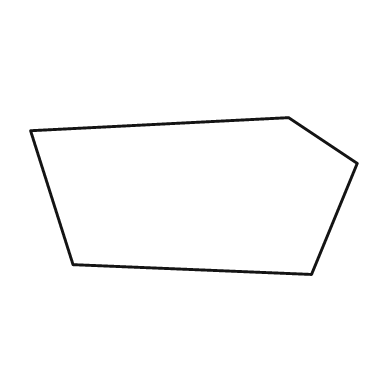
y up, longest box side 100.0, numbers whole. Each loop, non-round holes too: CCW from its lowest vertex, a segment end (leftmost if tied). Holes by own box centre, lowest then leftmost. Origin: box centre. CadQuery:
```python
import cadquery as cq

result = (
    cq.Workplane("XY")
    .moveTo(36.0, -24.0)
    .lineTo(50.0, 10.0)
    .lineTo(29.0, 24.0)
    .lineTo(-50.0, 20.0)
    .lineTo(-37.0, -21.0)
    .close()
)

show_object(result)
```